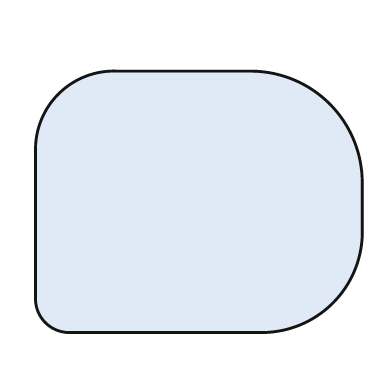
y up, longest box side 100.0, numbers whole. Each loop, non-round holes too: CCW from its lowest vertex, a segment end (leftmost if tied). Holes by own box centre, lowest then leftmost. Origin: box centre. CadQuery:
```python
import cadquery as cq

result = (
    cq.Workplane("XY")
    .moveTo(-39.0, -40.0)
    .lineTo(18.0, -40.0)
    .threePointArc((41.0, -31.0), (50.0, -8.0))
    .lineTo(50.0, 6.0)
    .threePointArc((40.0, 30.0), (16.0, 40.0))
    .lineTo(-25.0, 40.0)
    .threePointArc((-43.0, 33.0), (-50.0, 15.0))
    .lineTo(-50.0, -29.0)
    .threePointArc((-47.0, -37.0), (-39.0, -40.0))
    .close()
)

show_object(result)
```